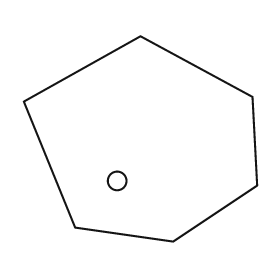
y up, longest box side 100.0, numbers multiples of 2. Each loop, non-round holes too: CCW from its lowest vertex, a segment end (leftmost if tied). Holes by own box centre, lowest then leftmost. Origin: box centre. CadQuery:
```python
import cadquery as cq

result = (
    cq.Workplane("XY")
    .moveTo(14.0, -44.0)
    .lineTo(50.0, -20.0)
    .lineTo(48.0, 18.0)
    .lineTo(0.0, 44.0)
    .lineTo(-50.0, 16.0)
    .lineTo(-28.0, -38.0)
    .close()
    .moveTo(-10.0, -18.0)
    .circle(4.0)
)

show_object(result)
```